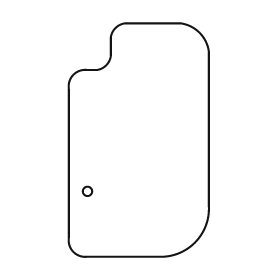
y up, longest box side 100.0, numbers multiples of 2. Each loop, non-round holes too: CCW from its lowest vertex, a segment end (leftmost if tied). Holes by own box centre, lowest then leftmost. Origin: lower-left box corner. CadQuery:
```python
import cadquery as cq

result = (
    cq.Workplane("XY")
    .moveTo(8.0, 0.0)
    .lineTo(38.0, 0.0)
    .threePointArc((54.0, 6.0), (60.0, 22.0))
    .lineTo(60.0, 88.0)
    .threePointArc((56.0, 96.0), (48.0, 100.0))
    .lineTo(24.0, 100.0)
    .threePointArc((20.0, 98.0), (18.0, 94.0))
    .lineTo(18.0, 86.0)
    .threePointArc((16.0, 82.0), (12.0, 80.0))
    .lineTo(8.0, 80.0)
    .threePointArc((2.0, 78.0), (0.0, 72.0))
    .lineTo(0.0, 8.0)
    .threePointArc((2.0, 2.0), (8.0, 0.0))
    .close()
    .moveTo(8.0, 28.0)
    .circle(2.0)
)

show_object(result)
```